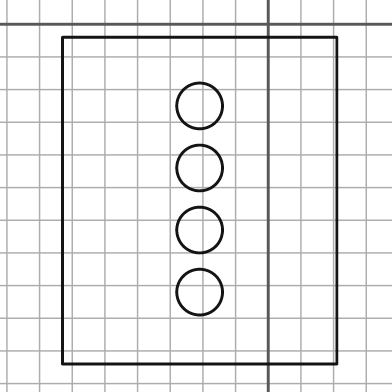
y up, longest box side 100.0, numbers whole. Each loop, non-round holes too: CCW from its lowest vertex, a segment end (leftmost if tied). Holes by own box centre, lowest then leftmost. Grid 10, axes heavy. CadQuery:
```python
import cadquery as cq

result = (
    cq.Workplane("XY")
    .moveTo(-63.0, -104.0)
    .lineTo(21.0, -104.0)
    .lineTo(21.0, -4.0)
    .lineTo(-63.0, -4.0)
    .close()
    .moveTo(-21.0, -82.0)
    .circle(7.0)
    .moveTo(-21.0, -63.0)
    .circle(7.0)
    .moveTo(-21.0, -44.0)
    .circle(7.0)
    .moveTo(-21.0, -25.0)
    .circle(7.0)
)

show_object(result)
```